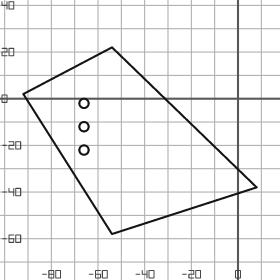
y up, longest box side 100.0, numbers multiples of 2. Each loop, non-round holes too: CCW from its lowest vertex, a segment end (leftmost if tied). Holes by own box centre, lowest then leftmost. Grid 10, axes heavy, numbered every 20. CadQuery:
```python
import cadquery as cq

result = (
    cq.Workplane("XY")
    .moveTo(-54.0, -58.0)
    .lineTo(8.0, -38.0)
    .lineTo(-54.0, 22.0)
    .lineTo(-92.0, 2.0)
    .close()
    .moveTo(-66.0, -22.0)
    .circle(2.0)
    .moveTo(-66.0, -12.0)
    .circle(2.0)
    .moveTo(-66.0, -2.0)
    .circle(2.0)
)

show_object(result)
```